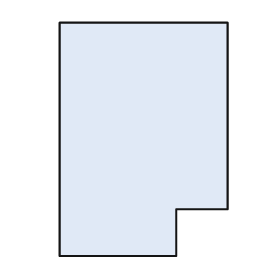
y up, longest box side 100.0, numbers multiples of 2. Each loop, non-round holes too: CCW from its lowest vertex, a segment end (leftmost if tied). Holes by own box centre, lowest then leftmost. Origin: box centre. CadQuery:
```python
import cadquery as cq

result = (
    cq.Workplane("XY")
    .moveTo(-36.0, -50.0)
    .lineTo(14.0, -50.0)
    .lineTo(14.0, -30.0)
    .lineTo(36.0, -30.0)
    .lineTo(36.0, 50.0)
    .lineTo(-36.0, 50.0)
    .close()
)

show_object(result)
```